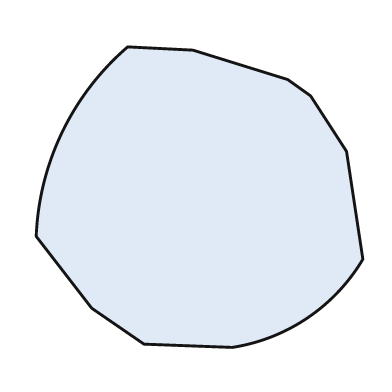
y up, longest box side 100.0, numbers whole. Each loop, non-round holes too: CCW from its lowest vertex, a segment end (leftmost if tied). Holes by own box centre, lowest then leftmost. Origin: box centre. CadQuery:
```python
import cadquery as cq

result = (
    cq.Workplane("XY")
    .moveTo(10.0, -46.0)
    .threePointArc((33.0, -37.0), (50.0, -19.0))
    .lineTo(45.0, 14.0)
    .lineTo(34.0, 31.0)
    .lineTo(27.0, 36.0)
    .lineTo(-2.0, 45.0)
    .lineTo(-22.0, 46.0)
    .threePointArc((-42.0, 20.0), (-50.0, -12.0))
    .lineTo(-33.0, -34.0)
    .lineTo(-17.0, -45.0)
    .close()
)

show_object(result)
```